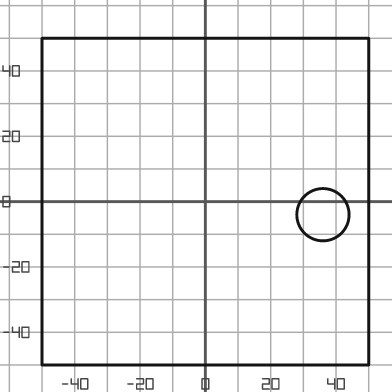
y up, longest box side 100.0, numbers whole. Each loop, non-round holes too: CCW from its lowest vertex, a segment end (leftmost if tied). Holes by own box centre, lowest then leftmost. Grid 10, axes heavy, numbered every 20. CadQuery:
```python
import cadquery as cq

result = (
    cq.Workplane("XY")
    .moveTo(-50.0, -50.0)
    .lineTo(50.0, -50.0)
    .lineTo(50.0, 50.0)
    .lineTo(-50.0, 50.0)
    .close()
    .moveTo(36.0, -4.0)
    .circle(8.0)
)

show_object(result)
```